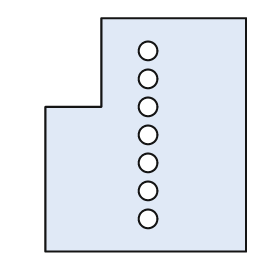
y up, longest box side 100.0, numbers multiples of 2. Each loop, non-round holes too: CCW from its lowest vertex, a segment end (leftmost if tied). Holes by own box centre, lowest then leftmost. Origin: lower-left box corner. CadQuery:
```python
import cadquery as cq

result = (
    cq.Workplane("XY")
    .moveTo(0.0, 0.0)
    .lineTo(86.0, 0.0)
    .lineTo(86.0, 100.0)
    .lineTo(24.0, 100.0)
    .lineTo(24.0, 62.0)
    .lineTo(0.0, 62.0)
    .close()
    .moveTo(44.0, 14.0)
    .circle(4.0)
    .moveTo(44.0, 26.0)
    .circle(4.0)
    .moveTo(44.0, 38.0)
    .circle(4.0)
    .moveTo(44.0, 50.0)
    .circle(4.0)
    .moveTo(44.0, 62.0)
    .circle(4.0)
    .moveTo(44.0, 74.0)
    .circle(4.0)
    .moveTo(44.0, 86.0)
    .circle(4.0)
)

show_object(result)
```